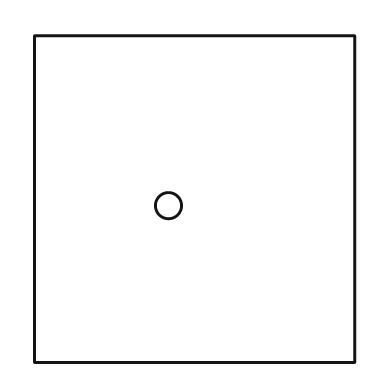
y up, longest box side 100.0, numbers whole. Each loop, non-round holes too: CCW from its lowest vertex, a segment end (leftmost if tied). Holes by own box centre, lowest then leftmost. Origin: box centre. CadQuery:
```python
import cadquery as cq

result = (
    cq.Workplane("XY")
    .moveTo(-49.0, -50.0)
    .lineTo(49.0, -50.0)
    .lineTo(49.0, 50.0)
    .lineTo(-49.0, 50.0)
    .close()
    .moveTo(-8.0, -2.0)
    .circle(4.0)
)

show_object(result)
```